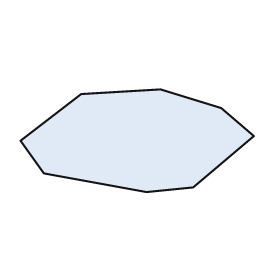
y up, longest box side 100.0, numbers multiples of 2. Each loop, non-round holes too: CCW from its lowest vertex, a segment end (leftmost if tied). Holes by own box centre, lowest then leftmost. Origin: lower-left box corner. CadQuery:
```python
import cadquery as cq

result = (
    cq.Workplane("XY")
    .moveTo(54.0, 0.0)
    .lineTo(74.0, 2.0)
    .lineTo(100.0, 24.0)
    .lineTo(86.0, 36.0)
    .lineTo(60.0, 44.0)
    .lineTo(26.0, 42.0)
    .lineTo(0.0, 22.0)
    .lineTo(10.0, 8.0)
    .close()
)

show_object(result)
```